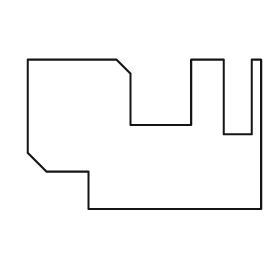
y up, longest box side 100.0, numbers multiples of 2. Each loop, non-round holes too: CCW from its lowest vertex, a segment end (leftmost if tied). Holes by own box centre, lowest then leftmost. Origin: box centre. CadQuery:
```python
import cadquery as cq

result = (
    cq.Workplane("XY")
    .moveTo(-24.0, -32.0)
    .lineTo(50.0, -32.0)
    .lineTo(50.0, 32.0)
    .lineTo(46.0, 32.0)
    .lineTo(46.0, 0.0)
    .lineTo(34.0, 0.0)
    .lineTo(34.0, 32.0)
    .lineTo(20.0, 32.0)
    .lineTo(20.0, 4.0)
    .lineTo(-6.0, 4.0)
    .lineTo(-6.0, 26.0)
    .lineTo(-12.0, 32.0)
    .lineTo(-50.0, 32.0)
    .lineTo(-50.0, -8.0)
    .lineTo(-42.0, -16.0)
    .lineTo(-24.0, -16.0)
    .close()
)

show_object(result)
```